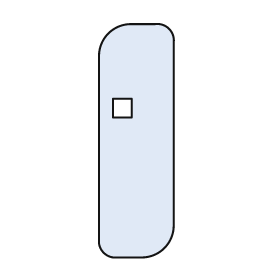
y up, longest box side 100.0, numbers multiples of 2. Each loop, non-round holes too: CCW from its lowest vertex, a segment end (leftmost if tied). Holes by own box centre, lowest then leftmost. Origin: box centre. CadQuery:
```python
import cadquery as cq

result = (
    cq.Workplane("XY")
    .moveTo(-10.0, -50.0)
    .lineTo(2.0, -50.0)
    .threePointArc((12.0, -46.0), (16.0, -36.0))
    .lineTo(16.0, 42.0)
    .threePointArc((14.0, 48.0), (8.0, 50.0))
    .lineTo(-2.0, 50.0)
    .threePointArc((-12.0, 46.0), (-16.0, 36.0))
    .lineTo(-16.0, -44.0)
    .threePointArc((-14.0, -48.0), (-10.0, -50.0))
    .close()
    .moveTo(-10.0, 10.0)
    .lineTo(-2.0, 10.0)
    .lineTo(-2.0, 18.0)
    .lineTo(-10.0, 18.0)
    .close()
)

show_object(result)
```